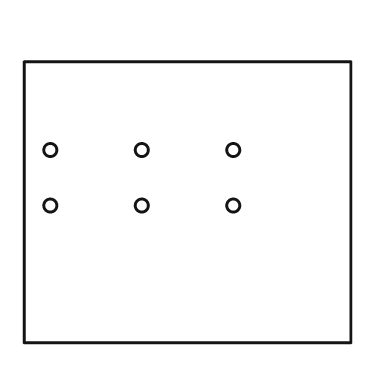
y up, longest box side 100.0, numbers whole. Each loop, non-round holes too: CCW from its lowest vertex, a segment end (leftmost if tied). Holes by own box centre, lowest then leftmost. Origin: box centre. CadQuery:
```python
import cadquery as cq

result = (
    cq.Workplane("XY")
    .moveTo(-50.0, -43.0)
    .lineTo(50.0, -43.0)
    .lineTo(50.0, 43.0)
    .lineTo(-50.0, 43.0)
    .close()
    .moveTo(-42.0, -1.0)
    .circle(2.0)
    .moveTo(-14.0, -1.0)
    .circle(2.0)
    .moveTo(14.0, -1.0)
    .circle(2.0)
    .moveTo(-42.0, 16.0)
    .circle(2.0)
    .moveTo(-14.0, 16.0)
    .circle(2.0)
    .moveTo(14.0, 16.0)
    .circle(2.0)
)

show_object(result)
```